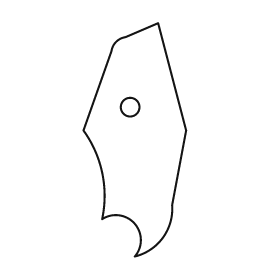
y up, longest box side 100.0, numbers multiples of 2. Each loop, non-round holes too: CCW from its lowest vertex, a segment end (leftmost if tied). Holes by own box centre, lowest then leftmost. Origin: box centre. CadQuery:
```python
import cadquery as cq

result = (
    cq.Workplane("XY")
    .moveTo(0.0, -50.0)
    .threePointArc((12.0, -42.0), (16.0, -28.0))
    .lineTo(22.0, 4.0)
    .lineTo(10.0, 50.0)
    .lineTo(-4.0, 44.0)
    .threePointArc((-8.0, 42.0), (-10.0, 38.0))
    .lineTo(-22.0, 4.0)
    .threePointArc((-14.0, -14.0), (-14.0, -34.0))
    .threePointArc((0.0, -36.0), (0.0, -50.0))
    .close()
    .moveTo(-2.0, 14.0)
    .circle(4.0)
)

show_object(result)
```